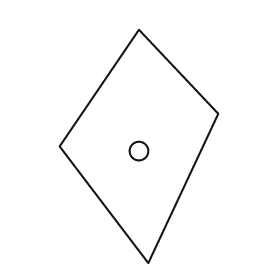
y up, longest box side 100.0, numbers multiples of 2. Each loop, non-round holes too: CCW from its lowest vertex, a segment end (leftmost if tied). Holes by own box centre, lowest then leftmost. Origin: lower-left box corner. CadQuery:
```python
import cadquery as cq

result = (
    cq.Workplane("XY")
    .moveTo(38.0, 0.0)
    .lineTo(68.0, 64.0)
    .lineTo(34.0, 100.0)
    .lineTo(0.0, 50.0)
    .close()
    .moveTo(34.0, 48.0)
    .circle(4.0)
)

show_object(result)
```